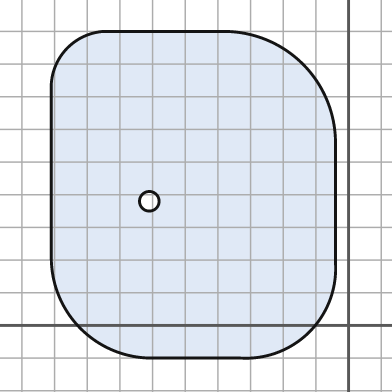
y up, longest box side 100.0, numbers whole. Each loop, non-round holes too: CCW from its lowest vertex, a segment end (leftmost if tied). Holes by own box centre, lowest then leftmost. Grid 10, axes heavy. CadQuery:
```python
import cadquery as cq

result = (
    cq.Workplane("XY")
    .moveTo(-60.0, -10.0)
    .lineTo(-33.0, -10.0)
    .threePointArc((-12.0, -2.0), (-4.0, 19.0))
    .lineTo(-4.0, 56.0)
    .threePointArc((-14.0, 80.0), (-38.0, 90.0))
    .lineTo(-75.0, 90.0)
    .threePointArc((-86.0, 85.0), (-91.0, 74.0))
    .lineTo(-91.0, 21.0)
    .threePointArc((-82.0, -1.0), (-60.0, -10.0))
    .close()
    .moveTo(-61.0, 38.0)
    .circle(3.0)
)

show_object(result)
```